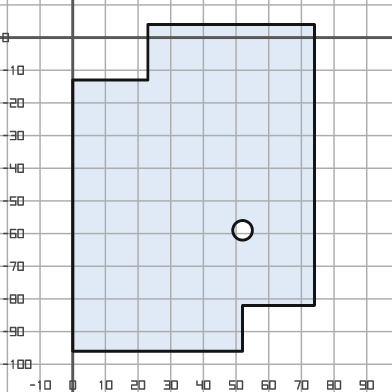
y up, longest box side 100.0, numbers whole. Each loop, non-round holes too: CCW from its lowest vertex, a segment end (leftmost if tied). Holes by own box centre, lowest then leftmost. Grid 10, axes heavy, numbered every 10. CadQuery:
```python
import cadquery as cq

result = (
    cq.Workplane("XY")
    .moveTo(0.0, -96.0)
    .lineTo(52.0, -96.0)
    .lineTo(52.0, -82.0)
    .lineTo(74.0, -82.0)
    .lineTo(74.0, 4.0)
    .lineTo(23.0, 4.0)
    .lineTo(23.0, -13.0)
    .lineTo(0.0, -13.0)
    .close()
    .moveTo(52.0, -59.0)
    .circle(3.0)
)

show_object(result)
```